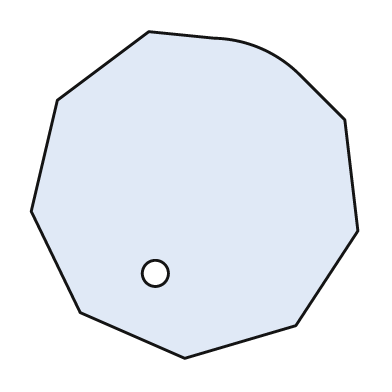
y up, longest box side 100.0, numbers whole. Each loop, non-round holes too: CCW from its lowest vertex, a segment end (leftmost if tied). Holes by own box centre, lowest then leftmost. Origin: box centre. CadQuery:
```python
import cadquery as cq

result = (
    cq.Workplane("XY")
    .moveTo(-3.0, -50.0)
    .lineTo(31.0, -40.0)
    .lineTo(50.0, -11.0)
    .lineTo(46.0, 23.0)
    .lineTo(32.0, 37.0)
    .threePointArc((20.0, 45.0), (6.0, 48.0))
    .lineTo(-14.0, 50.0)
    .lineTo(-42.0, 29.0)
    .lineTo(-50.0, -5.0)
    .lineTo(-35.0, -36.0)
    .close()
    .moveTo(-12.0, -24.0)
    .circle(4.0)
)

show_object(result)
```